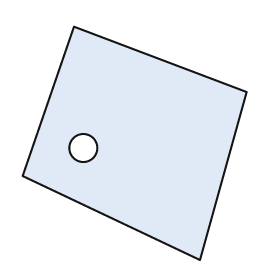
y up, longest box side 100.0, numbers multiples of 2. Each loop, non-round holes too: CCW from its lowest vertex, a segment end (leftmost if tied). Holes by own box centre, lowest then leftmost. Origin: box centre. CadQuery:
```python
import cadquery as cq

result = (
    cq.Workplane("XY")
    .moveTo(28.0, -50.0)
    .lineTo(48.0, 22.0)
    .lineTo(-26.0, 50.0)
    .lineTo(-48.0, -14.0)
    .close()
    .moveTo(-22.0, -2.0)
    .circle(6.0)
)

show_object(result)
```